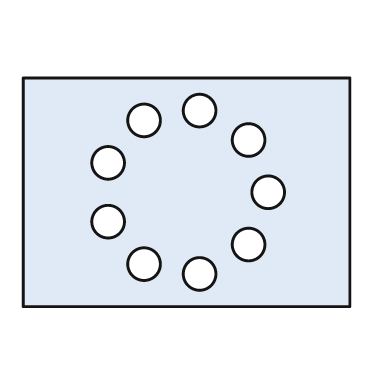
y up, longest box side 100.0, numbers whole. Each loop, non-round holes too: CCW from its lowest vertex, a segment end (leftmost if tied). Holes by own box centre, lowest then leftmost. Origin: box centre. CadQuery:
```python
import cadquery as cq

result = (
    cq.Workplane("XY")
    .moveTo(-50.0, -35.0)
    .lineTo(50.0, -35.0)
    .lineTo(50.0, 35.0)
    .lineTo(-50.0, 35.0)
    .close()
    .moveTo(4.0, -25.0)
    .circle(5.0)
    .moveTo(-13.0, -22.0)
    .circle(5.0)
    .moveTo(19.0, -16.0)
    .circle(5.0)
    .moveTo(-24.0, -9.0)
    .circle(5.0)
    .moveTo(25.0, 0.0)
    .circle(5.0)
    .moveTo(-24.0, 9.0)
    .circle(5.0)
    .moveTo(19.0, 16.0)
    .circle(5.0)
    .moveTo(-13.0, 22.0)
    .circle(5.0)
    .moveTo(4.0, 25.0)
    .circle(5.0)
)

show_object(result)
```